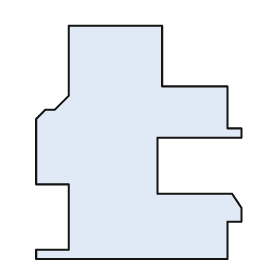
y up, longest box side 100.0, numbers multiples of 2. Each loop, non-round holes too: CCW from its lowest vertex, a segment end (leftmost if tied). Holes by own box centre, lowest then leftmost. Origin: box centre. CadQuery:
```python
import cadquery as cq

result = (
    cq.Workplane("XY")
    .moveTo(-44.0, -50.0)
    .lineTo(38.0, -50.0)
    .lineTo(38.0, -34.0)
    .lineTo(44.0, -34.0)
    .lineTo(44.0, -28.0)
    .lineTo(40.0, -22.0)
    .lineTo(8.0, -22.0)
    .lineTo(8.0, 2.0)
    .lineTo(44.0, 2.0)
    .lineTo(44.0, 6.0)
    .lineTo(38.0, 6.0)
    .lineTo(38.0, 24.0)
    .lineTo(10.0, 24.0)
    .lineTo(10.0, 50.0)
    .lineTo(-30.0, 50.0)
    .lineTo(-30.0, 20.0)
    .lineTo(-36.0, 14.0)
    .lineTo(-40.0, 14.0)
    .lineTo(-44.0, 10.0)
    .lineTo(-44.0, -18.0)
    .lineTo(-30.0, -18.0)
    .lineTo(-30.0, -46.0)
    .lineTo(-44.0, -46.0)
    .close()
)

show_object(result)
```